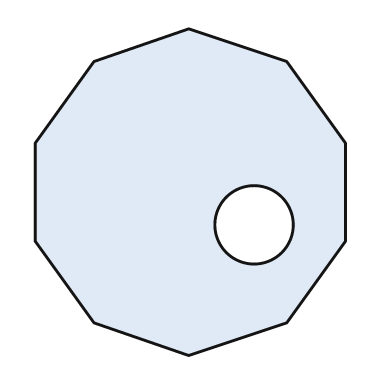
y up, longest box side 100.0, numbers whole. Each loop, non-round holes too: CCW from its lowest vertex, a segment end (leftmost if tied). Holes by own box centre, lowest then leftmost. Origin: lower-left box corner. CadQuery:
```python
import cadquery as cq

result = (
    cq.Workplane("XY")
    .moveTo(47.0, 0.0)
    .lineTo(77.0, 10.0)
    .lineTo(95.0, 35.0)
    .lineTo(95.0, 65.0)
    .lineTo(77.0, 90.0)
    .lineTo(47.0, 100.0)
    .lineTo(18.0, 90.0)
    .lineTo(0.0, 65.0)
    .lineTo(0.0, 35.0)
    .lineTo(18.0, 10.0)
    .close()
    .moveTo(67.0, 40.0)
    .circle(12.0)
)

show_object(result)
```